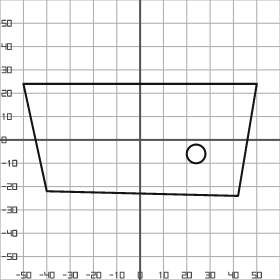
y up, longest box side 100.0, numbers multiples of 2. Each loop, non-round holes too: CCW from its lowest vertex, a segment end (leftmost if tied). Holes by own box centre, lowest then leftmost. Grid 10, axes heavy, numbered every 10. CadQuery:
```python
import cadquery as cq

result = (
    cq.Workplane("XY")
    .moveTo(42.0, -24.0)
    .lineTo(50.0, 24.0)
    .lineTo(-50.0, 24.0)
    .lineTo(-40.0, -22.0)
    .close()
    .moveTo(24.0, -6.0)
    .circle(4.0)
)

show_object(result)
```